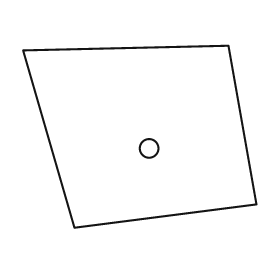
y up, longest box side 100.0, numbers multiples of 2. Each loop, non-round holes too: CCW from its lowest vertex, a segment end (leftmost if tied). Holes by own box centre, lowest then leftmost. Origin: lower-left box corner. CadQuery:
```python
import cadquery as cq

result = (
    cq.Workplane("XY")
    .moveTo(22.0, 0.0)
    .lineTo(100.0, 10.0)
    .lineTo(88.0, 78.0)
    .lineTo(0.0, 76.0)
    .close()
    .moveTo(54.0, 34.0)
    .circle(4.0)
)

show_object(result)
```